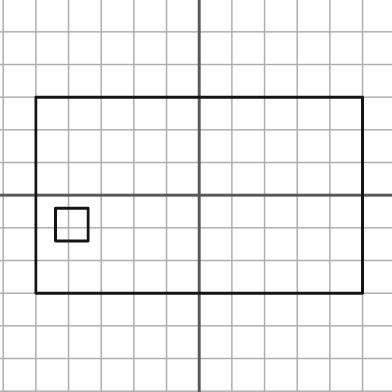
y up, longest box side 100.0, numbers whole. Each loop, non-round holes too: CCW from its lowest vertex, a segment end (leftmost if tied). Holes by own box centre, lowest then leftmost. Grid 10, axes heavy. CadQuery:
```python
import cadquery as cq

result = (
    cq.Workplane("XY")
    .moveTo(-50.0, -30.0)
    .lineTo(50.0, -30.0)
    .lineTo(50.0, 30.0)
    .lineTo(-50.0, 30.0)
    .close()
    .moveTo(-44.0, -14.0)
    .lineTo(-34.0, -14.0)
    .lineTo(-34.0, -4.0)
    .lineTo(-44.0, -4.0)
    .close()
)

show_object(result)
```